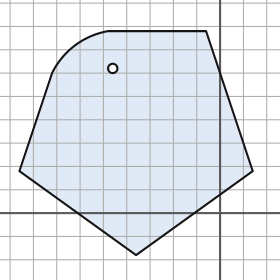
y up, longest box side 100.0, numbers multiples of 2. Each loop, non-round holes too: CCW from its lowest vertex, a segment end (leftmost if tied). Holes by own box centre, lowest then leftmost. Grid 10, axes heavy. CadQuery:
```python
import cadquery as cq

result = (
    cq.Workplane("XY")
    .moveTo(-36.0, -18.0)
    .lineTo(14.0, 18.0)
    .lineTo(-6.0, 78.0)
    .lineTo(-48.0, 78.0)
    .threePointArc((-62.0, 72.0), (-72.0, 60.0))
    .lineTo(-86.0, 18.0)
    .close()
    .moveTo(-46.0, 62.0)
    .circle(2.0)
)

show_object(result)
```